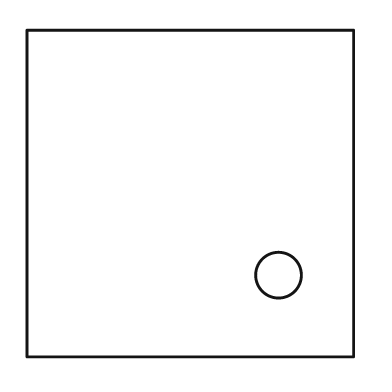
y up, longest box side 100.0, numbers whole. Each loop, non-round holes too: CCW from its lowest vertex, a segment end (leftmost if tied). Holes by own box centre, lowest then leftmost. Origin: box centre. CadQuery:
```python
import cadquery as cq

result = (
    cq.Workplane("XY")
    .moveTo(-50.0, -50.0)
    .lineTo(50.0, -50.0)
    .lineTo(50.0, 50.0)
    .lineTo(-50.0, 50.0)
    .close()
    .moveTo(27.0, -25.0)
    .circle(7.0)
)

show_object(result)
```